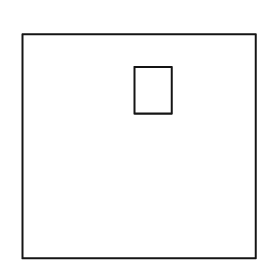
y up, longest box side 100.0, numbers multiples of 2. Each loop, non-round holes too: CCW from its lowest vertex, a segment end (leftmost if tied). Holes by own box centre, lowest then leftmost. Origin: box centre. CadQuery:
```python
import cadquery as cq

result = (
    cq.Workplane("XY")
    .moveTo(-50.0, -48.0)
    .lineTo(50.0, -48.0)
    .lineTo(50.0, 48.0)
    .lineTo(-50.0, 48.0)
    .close()
    .moveTo(-2.0, 14.0)
    .lineTo(14.0, 14.0)
    .lineTo(14.0, 34.0)
    .lineTo(-2.0, 34.0)
    .close()
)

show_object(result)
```